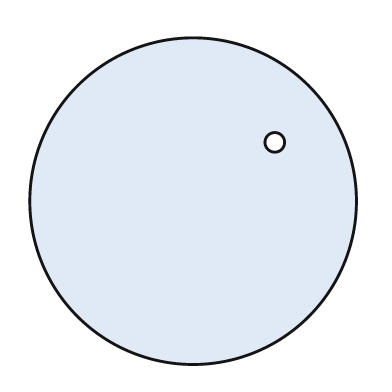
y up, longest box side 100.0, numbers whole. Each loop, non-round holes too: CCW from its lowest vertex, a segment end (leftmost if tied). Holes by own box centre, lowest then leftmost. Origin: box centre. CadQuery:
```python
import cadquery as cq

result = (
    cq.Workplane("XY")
    .moveTo(0.0, 0.0)
    .circle(50.0)
    .moveTo(25.0, 18.0)
    .circle(3.0)
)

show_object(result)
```